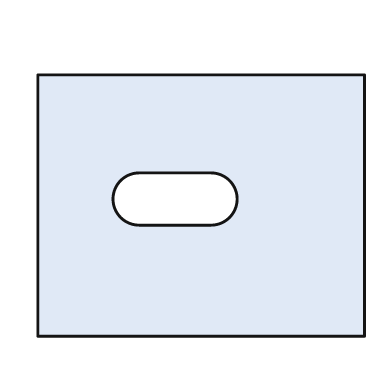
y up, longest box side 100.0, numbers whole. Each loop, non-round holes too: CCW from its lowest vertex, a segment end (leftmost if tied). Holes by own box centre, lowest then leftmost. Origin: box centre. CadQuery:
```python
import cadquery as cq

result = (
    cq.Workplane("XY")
    .moveTo(-50.0, -40.0)
    .lineTo(50.0, -40.0)
    .lineTo(50.0, 40.0)
    .lineTo(-50.0, 40.0)
    .close()
    .moveTo(-19.0, -6.0)
    .lineTo(3.0, -6.0)
    .threePointArc((11.0, 2.0), (3.0, 10.0))
    .lineTo(-19.0, 10.0)
    .threePointArc((-27.0, 2.0), (-19.0, -6.0))
    .close()
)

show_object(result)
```